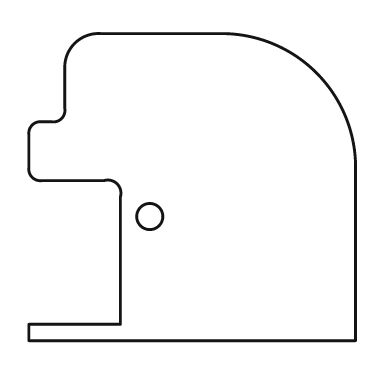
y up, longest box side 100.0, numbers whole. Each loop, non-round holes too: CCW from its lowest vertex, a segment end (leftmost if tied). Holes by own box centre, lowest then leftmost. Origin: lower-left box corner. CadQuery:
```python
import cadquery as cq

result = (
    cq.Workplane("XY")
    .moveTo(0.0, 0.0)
    .lineTo(100.0, 0.0)
    .lineTo(100.0, 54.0)
    .threePointArc((88.0, 82.0), (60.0, 94.0))
    .lineTo(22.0, 94.0)
    .threePointArc((14.0, 91.0), (11.0, 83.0))
    .lineTo(11.0, 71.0)
    .threePointArc((10.0, 68.0), (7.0, 67.0))
    .lineTo(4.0, 67.0)
    .threePointArc((1.0, 66.0), (0.0, 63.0))
    .lineTo(0.0, 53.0)
    .threePointArc((1.0, 50.0), (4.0, 49.0))
    .lineTo(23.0, 49.0)
    .threePointArc((27.0, 48.0), (28.0, 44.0))
    .lineTo(28.0, 5.0)
    .lineTo(0.0, 5.0)
    .close()
    .moveTo(37.0, 38.0)
    .circle(4.0)
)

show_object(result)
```